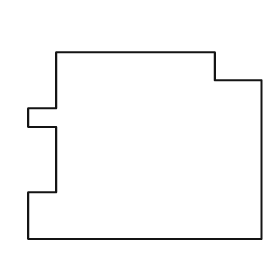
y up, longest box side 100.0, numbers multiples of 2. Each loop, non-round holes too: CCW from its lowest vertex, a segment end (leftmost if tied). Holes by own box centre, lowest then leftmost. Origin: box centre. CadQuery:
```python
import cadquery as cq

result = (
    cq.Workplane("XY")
    .moveTo(-50.0, -40.0)
    .lineTo(50.0, -40.0)
    .lineTo(50.0, 28.0)
    .lineTo(30.0, 28.0)
    .lineTo(30.0, 40.0)
    .lineTo(-38.0, 40.0)
    .lineTo(-38.0, 16.0)
    .lineTo(-50.0, 16.0)
    .lineTo(-50.0, 8.0)
    .lineTo(-38.0, 8.0)
    .lineTo(-38.0, -20.0)
    .lineTo(-50.0, -20.0)
    .close()
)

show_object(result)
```